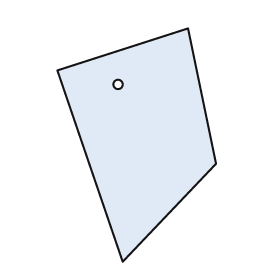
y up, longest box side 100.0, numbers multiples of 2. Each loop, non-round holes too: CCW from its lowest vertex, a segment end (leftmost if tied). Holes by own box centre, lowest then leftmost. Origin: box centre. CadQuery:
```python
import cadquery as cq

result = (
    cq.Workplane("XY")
    .moveTo(-6.0, -50.0)
    .lineTo(34.0, -8.0)
    .lineTo(22.0, 50.0)
    .lineTo(-34.0, 32.0)
    .close()
    .moveTo(-8.0, 26.0)
    .circle(2.0)
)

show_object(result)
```